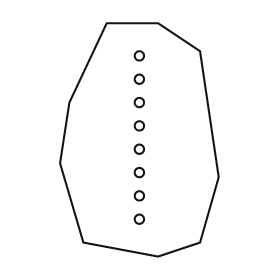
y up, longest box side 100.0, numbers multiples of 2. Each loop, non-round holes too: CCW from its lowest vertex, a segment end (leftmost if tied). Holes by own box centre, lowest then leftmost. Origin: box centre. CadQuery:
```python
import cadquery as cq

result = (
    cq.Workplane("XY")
    .moveTo(8.0, -50.0)
    .lineTo(26.0, -44.0)
    .lineTo(34.0, -16.0)
    .lineTo(26.0, 38.0)
    .lineTo(8.0, 50.0)
    .lineTo(-14.0, 50.0)
    .lineTo(-30.0, 16.0)
    .lineTo(-34.0, -10.0)
    .lineTo(-24.0, -44.0)
    .close()
    .moveTo(0.0, -34.0)
    .circle(2.0)
    .moveTo(0.0, -24.0)
    .circle(2.0)
    .moveTo(0.0, -14.0)
    .circle(2.0)
    .moveTo(0.0, -4.0)
    .circle(2.0)
    .moveTo(0.0, 6.0)
    .circle(2.0)
    .moveTo(0.0, 16.0)
    .circle(2.0)
    .moveTo(0.0, 26.0)
    .circle(2.0)
    .moveTo(0.0, 36.0)
    .circle(2.0)
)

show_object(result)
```